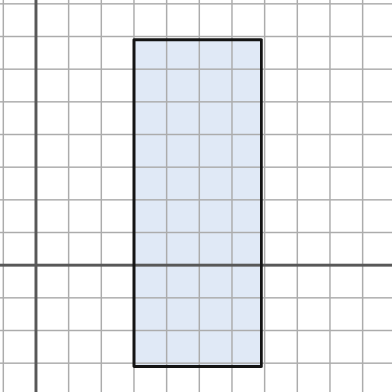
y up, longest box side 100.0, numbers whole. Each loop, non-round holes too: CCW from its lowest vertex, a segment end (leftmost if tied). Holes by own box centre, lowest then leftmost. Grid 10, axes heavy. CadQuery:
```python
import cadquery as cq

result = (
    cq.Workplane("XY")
    .moveTo(30.0, -31.0)
    .lineTo(69.0, -31.0)
    .lineTo(69.0, 69.0)
    .lineTo(30.0, 69.0)
    .close()
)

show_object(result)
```